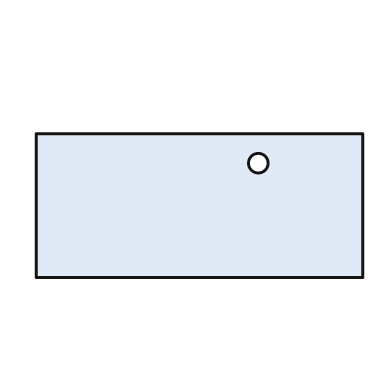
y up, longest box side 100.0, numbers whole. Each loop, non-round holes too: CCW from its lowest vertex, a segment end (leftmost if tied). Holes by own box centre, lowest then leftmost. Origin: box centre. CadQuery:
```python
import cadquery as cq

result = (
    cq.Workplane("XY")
    .moveTo(-50.0, -22.0)
    .lineTo(50.0, -22.0)
    .lineTo(50.0, 22.0)
    .lineTo(-50.0, 22.0)
    .close()
    .moveTo(18.0, 13.0)
    .circle(3.0)
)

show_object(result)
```